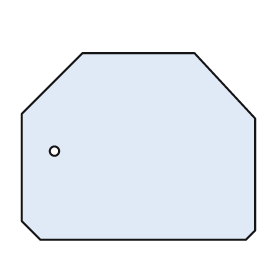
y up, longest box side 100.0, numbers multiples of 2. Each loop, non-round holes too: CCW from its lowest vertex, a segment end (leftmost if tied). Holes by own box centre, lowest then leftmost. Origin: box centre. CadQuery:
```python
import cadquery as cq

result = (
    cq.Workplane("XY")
    .moveTo(-42.0, -40.0)
    .lineTo(46.0, -40.0)
    .lineTo(50.0, -36.0)
    .lineTo(50.0, 12.0)
    .lineTo(24.0, 40.0)
    .lineTo(-24.0, 40.0)
    .lineTo(-50.0, 14.0)
    .lineTo(-50.0, -32.0)
    .close()
    .moveTo(-36.0, -2.0)
    .circle(2.0)
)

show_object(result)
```